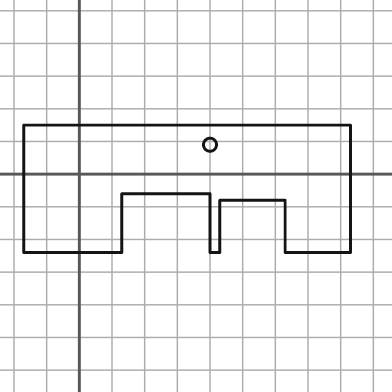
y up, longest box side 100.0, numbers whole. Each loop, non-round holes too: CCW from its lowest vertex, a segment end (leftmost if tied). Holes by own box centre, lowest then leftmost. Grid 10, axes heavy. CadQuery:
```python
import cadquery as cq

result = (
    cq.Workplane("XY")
    .moveTo(-17.0, -24.0)
    .lineTo(13.0, -24.0)
    .lineTo(13.0, -6.0)
    .lineTo(40.0, -6.0)
    .lineTo(40.0, -24.0)
    .lineTo(43.0, -24.0)
    .lineTo(43.0, -8.0)
    .lineTo(63.0, -8.0)
    .lineTo(63.0, -24.0)
    .lineTo(83.0, -24.0)
    .lineTo(83.0, 15.0)
    .lineTo(-17.0, 15.0)
    .close()
    .moveTo(40.0, 9.0)
    .circle(2.0)
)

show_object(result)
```